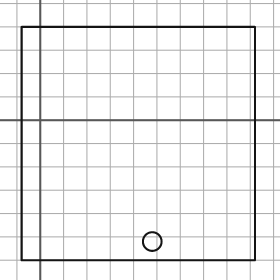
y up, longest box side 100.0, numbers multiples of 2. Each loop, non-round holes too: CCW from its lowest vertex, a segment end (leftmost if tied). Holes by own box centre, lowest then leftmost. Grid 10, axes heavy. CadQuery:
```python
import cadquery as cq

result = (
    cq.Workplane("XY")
    .moveTo(-8.0, -60.0)
    .lineTo(92.0, -60.0)
    .lineTo(92.0, 40.0)
    .lineTo(-8.0, 40.0)
    .close()
    .moveTo(48.0, -52.0)
    .circle(4.0)
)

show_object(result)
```